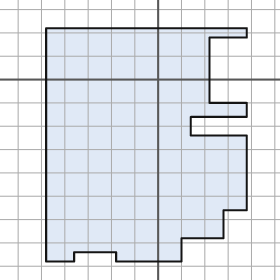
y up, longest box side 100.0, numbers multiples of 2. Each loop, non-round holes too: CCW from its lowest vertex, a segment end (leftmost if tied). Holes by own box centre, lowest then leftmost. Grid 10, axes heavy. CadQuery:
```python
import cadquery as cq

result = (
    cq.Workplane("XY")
    .moveTo(-48.0, -78.0)
    .lineTo(-36.0, -78.0)
    .lineTo(-36.0, -74.0)
    .lineTo(-18.0, -74.0)
    .lineTo(-18.0, -78.0)
    .lineTo(10.0, -78.0)
    .lineTo(10.0, -68.0)
    .lineTo(28.0, -68.0)
    .lineTo(28.0, -56.0)
    .lineTo(38.0, -56.0)
    .lineTo(38.0, -24.0)
    .lineTo(14.0, -24.0)
    .lineTo(14.0, -16.0)
    .lineTo(38.0, -16.0)
    .lineTo(38.0, -10.0)
    .lineTo(22.0, -10.0)
    .lineTo(22.0, 18.0)
    .lineTo(38.0, 18.0)
    .lineTo(38.0, 22.0)
    .lineTo(-48.0, 22.0)
    .close()
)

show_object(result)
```